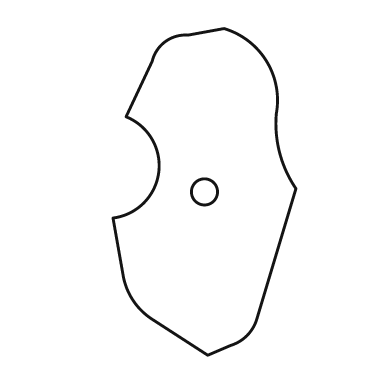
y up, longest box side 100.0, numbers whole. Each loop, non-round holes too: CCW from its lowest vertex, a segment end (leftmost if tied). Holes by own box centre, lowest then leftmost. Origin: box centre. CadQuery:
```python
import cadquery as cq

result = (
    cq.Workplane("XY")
    .moveTo(1.0, -50.0)
    .lineTo(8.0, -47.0)
    .threePointArc((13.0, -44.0), (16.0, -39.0))
    .lineTo(28.0, 1.0)
    .threePointArc((23.0, 12.0), (22.0, 24.0))
    .threePointArc((19.0, 40.0), (6.0, 50.0))
    .lineTo(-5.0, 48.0)
    .threePointArc((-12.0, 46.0), (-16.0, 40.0))
    .lineTo(-24.0, 23.0)
    .threePointArc((-14.0, 6.0), (-28.0, -8.0))
    .lineTo(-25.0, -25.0)
    .threePointArc((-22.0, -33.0), (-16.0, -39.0))
    .close()
    .moveTo(0.0, 0.0)
    .circle(4.0)
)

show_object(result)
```